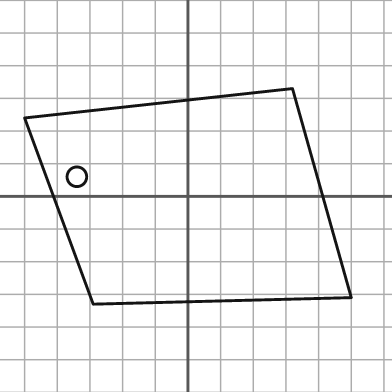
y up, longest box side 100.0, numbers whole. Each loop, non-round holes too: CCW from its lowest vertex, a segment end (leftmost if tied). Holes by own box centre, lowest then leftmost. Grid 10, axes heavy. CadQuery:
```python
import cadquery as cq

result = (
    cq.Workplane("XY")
    .moveTo(-29.0, -33.0)
    .lineTo(50.0, -31.0)
    .lineTo(32.0, 33.0)
    .lineTo(-50.0, 24.0)
    .close()
    .moveTo(-34.0, 6.0)
    .circle(3.0)
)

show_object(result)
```